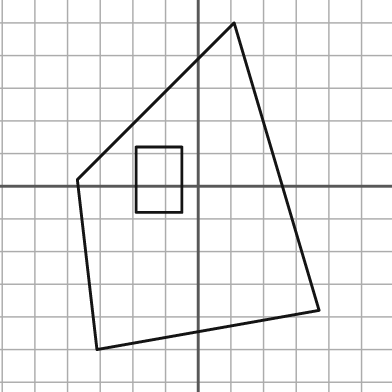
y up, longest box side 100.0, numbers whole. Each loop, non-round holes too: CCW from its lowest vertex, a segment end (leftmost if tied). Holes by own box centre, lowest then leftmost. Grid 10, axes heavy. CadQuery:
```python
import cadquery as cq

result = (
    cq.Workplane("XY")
    .moveTo(-31.0, -50.0)
    .lineTo(37.0, -38.0)
    .lineTo(11.0, 50.0)
    .lineTo(-37.0, 2.0)
    .close()
    .moveTo(-19.0, -8.0)
    .lineTo(-5.0, -8.0)
    .lineTo(-5.0, 12.0)
    .lineTo(-19.0, 12.0)
    .close()
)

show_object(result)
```